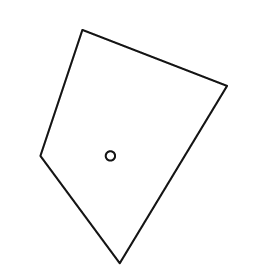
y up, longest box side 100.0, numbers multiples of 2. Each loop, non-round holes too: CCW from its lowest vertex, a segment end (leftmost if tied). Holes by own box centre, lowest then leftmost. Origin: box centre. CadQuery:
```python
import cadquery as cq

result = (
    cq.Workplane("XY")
    .moveTo(-6.0, -50.0)
    .lineTo(40.0, 26.0)
    .lineTo(-22.0, 50.0)
    .lineTo(-40.0, -4.0)
    .close()
    .moveTo(-10.0, -4.0)
    .circle(2.0)
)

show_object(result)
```